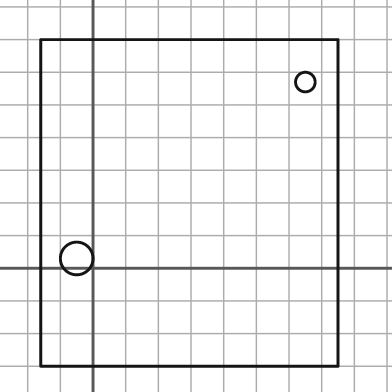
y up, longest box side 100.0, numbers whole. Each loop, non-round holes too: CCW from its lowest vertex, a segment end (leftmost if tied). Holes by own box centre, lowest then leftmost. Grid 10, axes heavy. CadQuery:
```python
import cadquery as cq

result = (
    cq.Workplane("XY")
    .moveTo(-16.0, -30.0)
    .lineTo(75.0, -30.0)
    .lineTo(75.0, 70.0)
    .lineTo(-16.0, 70.0)
    .close()
    .moveTo(-5.0, 3.0)
    .circle(5.0)
    .moveTo(65.0, 57.0)
    .circle(3.0)
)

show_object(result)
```